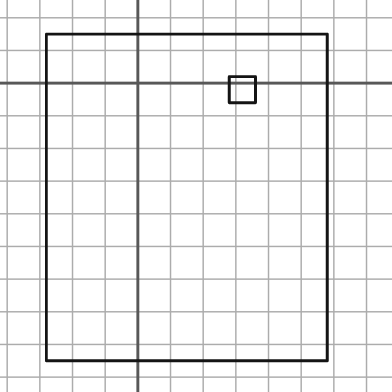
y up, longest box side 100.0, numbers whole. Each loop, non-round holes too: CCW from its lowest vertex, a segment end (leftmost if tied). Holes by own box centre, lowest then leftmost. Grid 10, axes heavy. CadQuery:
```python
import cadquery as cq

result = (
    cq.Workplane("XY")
    .moveTo(-28.0, -85.0)
    .lineTo(58.0, -85.0)
    .lineTo(58.0, 15.0)
    .lineTo(-28.0, 15.0)
    .close()
    .moveTo(28.0, -6.0)
    .lineTo(36.0, -6.0)
    .lineTo(36.0, 2.0)
    .lineTo(28.0, 2.0)
    .close()
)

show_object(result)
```